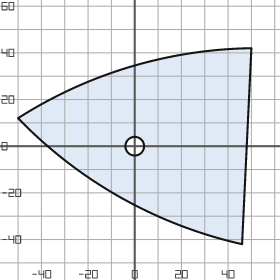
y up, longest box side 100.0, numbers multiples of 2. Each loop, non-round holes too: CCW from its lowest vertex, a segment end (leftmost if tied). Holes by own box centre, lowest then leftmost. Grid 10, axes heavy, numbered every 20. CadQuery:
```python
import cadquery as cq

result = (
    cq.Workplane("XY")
    .moveTo(46.0, -42.0)
    .lineTo(50.0, 42.0)
    .threePointArc((-2.0, 34.0), (-50.0, 12.0))
    .threePointArc((-6.0, -22.0), (46.0, -42.0))
    .close()
    .moveTo(0.0, 0.0)
    .circle(4.0)
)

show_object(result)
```